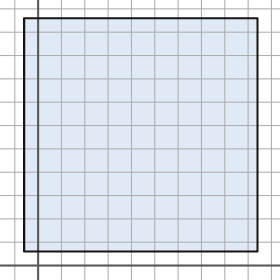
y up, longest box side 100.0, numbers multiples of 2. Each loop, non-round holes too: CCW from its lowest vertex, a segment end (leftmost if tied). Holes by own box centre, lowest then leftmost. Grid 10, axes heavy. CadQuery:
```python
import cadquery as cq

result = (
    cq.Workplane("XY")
    .moveTo(-6.0, 6.0)
    .lineTo(94.0, 6.0)
    .lineTo(94.0, 106.0)
    .lineTo(-6.0, 106.0)
    .close()
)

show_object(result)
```